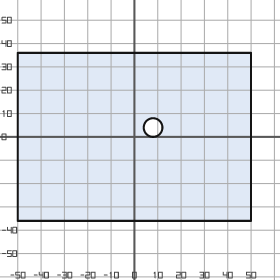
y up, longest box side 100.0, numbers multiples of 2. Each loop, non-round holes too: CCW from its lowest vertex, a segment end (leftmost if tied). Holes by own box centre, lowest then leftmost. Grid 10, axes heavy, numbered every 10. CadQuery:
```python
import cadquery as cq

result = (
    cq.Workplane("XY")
    .moveTo(-50.0, -36.0)
    .lineTo(50.0, -36.0)
    .lineTo(50.0, 36.0)
    .lineTo(-50.0, 36.0)
    .close()
    .moveTo(8.0, 4.0)
    .circle(4.0)
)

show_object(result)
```